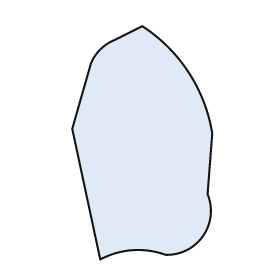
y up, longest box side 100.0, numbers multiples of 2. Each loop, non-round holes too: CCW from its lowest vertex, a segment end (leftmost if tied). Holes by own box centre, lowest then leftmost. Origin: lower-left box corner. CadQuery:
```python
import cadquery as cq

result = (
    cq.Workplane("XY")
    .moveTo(12.0, 0.0)
    .threePointArc((26.0, 4.0), (40.0, 2.0))
    .threePointArc((56.0, 10.0), (58.0, 28.0))
    .lineTo(60.0, 54.0)
    .threePointArc((50.0, 80.0), (30.0, 100.0))
    .lineTo(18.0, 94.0)
    .threePointArc((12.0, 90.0), (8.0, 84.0))
    .lineTo(0.0, 56.0)
    .close()
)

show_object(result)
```